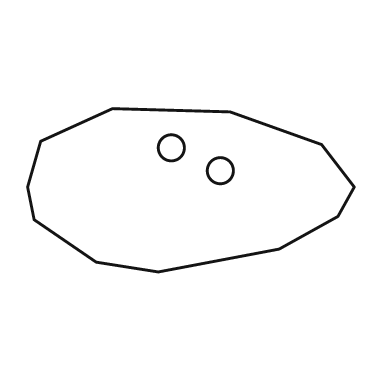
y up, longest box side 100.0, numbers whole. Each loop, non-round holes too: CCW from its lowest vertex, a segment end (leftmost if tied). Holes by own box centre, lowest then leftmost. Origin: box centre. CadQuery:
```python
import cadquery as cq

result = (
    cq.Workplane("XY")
    .moveTo(-10.0, -25.0)
    .lineTo(27.0, -18.0)
    .lineTo(45.0, -8.0)
    .lineTo(50.0, 1.0)
    .lineTo(40.0, 14.0)
    .lineTo(12.0, 24.0)
    .lineTo(-24.0, 25.0)
    .lineTo(-46.0, 15.0)
    .lineTo(-50.0, 1.0)
    .lineTo(-48.0, -9.0)
    .lineTo(-29.0, -22.0)
    .close()
    .moveTo(9.0, 6.0)
    .circle(4.0)
    .moveTo(-6.0, 13.0)
    .circle(4.0)
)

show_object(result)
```